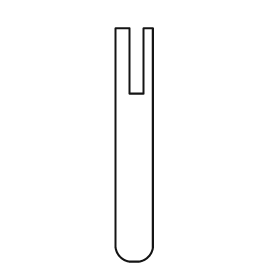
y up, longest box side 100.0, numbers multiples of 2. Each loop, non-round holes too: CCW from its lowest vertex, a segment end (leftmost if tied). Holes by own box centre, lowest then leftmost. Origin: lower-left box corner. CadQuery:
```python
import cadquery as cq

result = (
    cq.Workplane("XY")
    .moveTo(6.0, 0.0)
    .lineTo(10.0, 0.0)
    .threePointArc((14.0, 2.0), (16.0, 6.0))
    .lineTo(16.0, 100.0)
    .lineTo(12.0, 100.0)
    .lineTo(12.0, 72.0)
    .lineTo(6.0, 72.0)
    .lineTo(6.0, 100.0)
    .lineTo(0.0, 100.0)
    .lineTo(0.0, 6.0)
    .threePointArc((2.0, 2.0), (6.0, 0.0))
    .close()
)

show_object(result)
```